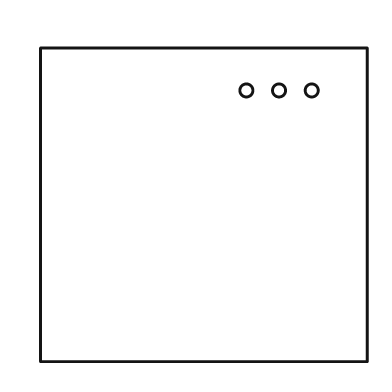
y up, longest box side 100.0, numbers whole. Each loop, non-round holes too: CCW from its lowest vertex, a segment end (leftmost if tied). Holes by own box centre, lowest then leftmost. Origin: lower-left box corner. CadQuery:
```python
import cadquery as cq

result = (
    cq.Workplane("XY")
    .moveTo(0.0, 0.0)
    .lineTo(100.0, 0.0)
    .lineTo(100.0, 96.0)
    .lineTo(0.0, 96.0)
    .close()
    .moveTo(63.0, 83.0)
    .circle(2.0)
    .moveTo(73.0, 83.0)
    .circle(2.0)
    .moveTo(83.0, 83.0)
    .circle(2.0)
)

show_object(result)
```